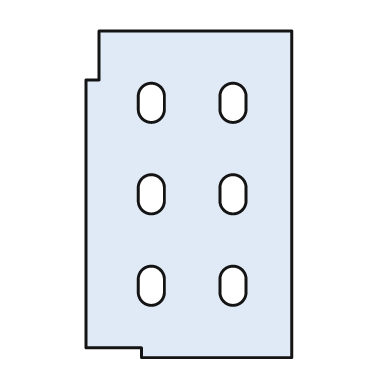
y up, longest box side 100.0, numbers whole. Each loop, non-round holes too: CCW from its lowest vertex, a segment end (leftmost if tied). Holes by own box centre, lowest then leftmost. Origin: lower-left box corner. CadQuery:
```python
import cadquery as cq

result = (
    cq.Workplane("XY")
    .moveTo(17.0, 0.0)
    .lineTo(63.0, 0.0)
    .lineTo(63.0, 100.0)
    .lineTo(4.0, 100.0)
    .lineTo(4.0, 85.0)
    .lineTo(0.0, 85.0)
    .lineTo(0.0, 3.0)
    .lineTo(17.0, 3.0)
    .close()
    .moveTo(16.0, 20.0)
    .threePointArc((20.0, 16.0), (24.0, 20.0))
    .lineTo(24.0, 24.0)
    .threePointArc((20.0, 28.0), (16.0, 24.0))
    .close()
    .moveTo(41.0, 20.0)
    .threePointArc((45.0, 16.0), (49.0, 20.0))
    .lineTo(49.0, 24.0)
    .threePointArc((45.0, 28.0), (41.0, 24.0))
    .close()
    .moveTo(16.0, 48.0)
    .threePointArc((20.0, 44.0), (24.0, 48.0))
    .lineTo(24.0, 52.0)
    .threePointArc((20.0, 56.0), (16.0, 52.0))
    .close()
    .moveTo(41.0, 48.0)
    .threePointArc((45.0, 44.0), (49.0, 48.0))
    .lineTo(49.0, 52.0)
    .threePointArc((45.0, 56.0), (41.0, 52.0))
    .close()
    .moveTo(16.0, 76.0)
    .threePointArc((20.0, 72.0), (24.0, 76.0))
    .lineTo(24.0, 80.0)
    .threePointArc((20.0, 84.0), (16.0, 80.0))
    .close()
    .moveTo(41.0, 76.0)
    .threePointArc((45.0, 72.0), (49.0, 76.0))
    .lineTo(49.0, 80.0)
    .threePointArc((45.0, 84.0), (41.0, 80.0))
    .close()
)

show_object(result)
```